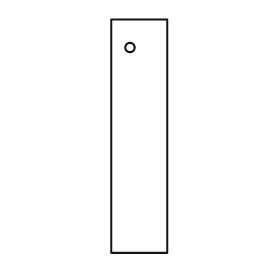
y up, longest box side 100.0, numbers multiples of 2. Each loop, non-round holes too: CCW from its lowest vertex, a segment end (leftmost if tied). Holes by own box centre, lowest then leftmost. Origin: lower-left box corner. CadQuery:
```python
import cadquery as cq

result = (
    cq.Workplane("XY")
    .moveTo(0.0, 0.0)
    .lineTo(24.0, 0.0)
    .lineTo(24.0, 100.0)
    .lineTo(0.0, 100.0)
    .close()
    .moveTo(8.0, 88.0)
    .circle(2.0)
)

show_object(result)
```